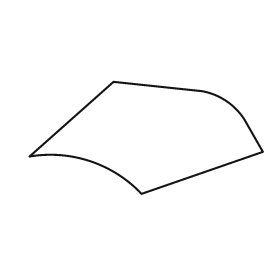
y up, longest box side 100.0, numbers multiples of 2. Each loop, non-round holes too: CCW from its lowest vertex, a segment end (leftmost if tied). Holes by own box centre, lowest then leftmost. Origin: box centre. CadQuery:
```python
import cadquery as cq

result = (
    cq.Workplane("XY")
    .moveTo(-2.0, -24.0)
    .lineTo(50.0, -6.0)
    .lineTo(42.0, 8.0)
    .threePointArc((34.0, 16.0), (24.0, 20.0))
    .lineTo(-14.0, 24.0)
    .lineTo(-50.0, -8.0)
    .threePointArc((-24.0, -10.0), (-2.0, -24.0))
    .close()
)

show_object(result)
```